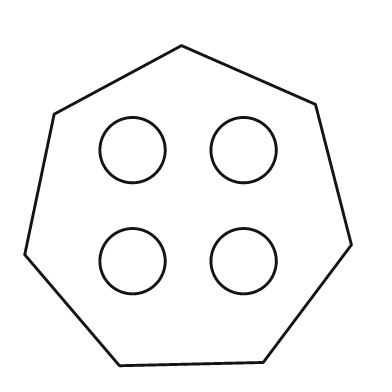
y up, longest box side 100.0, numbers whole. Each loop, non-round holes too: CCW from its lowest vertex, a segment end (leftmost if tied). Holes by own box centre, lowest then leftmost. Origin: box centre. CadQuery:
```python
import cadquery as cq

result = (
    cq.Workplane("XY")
    .moveTo(-21.0, -49.0)
    .lineTo(23.0, -48.0)
    .lineTo(50.0, -12.0)
    .lineTo(39.0, 31.0)
    .lineTo(-2.0, 49.0)
    .lineTo(-41.0, 28.0)
    .lineTo(-50.0, -15.0)
    .close()
    .moveTo(-17.0, -17.0)
    .circle(10.0)
    .moveTo(17.0, -17.0)
    .circle(10.0)
    .moveTo(-17.0, 17.0)
    .circle(10.0)
    .moveTo(17.0, 17.0)
    .circle(10.0)
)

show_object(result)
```